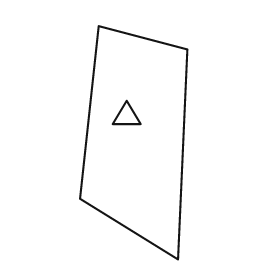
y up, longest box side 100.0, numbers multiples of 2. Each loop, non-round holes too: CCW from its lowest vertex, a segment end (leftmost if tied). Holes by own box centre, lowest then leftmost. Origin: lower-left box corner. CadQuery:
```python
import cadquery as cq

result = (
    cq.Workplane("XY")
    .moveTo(42.0, 0.0)
    .lineTo(46.0, 90.0)
    .lineTo(8.0, 100.0)
    .lineTo(0.0, 26.0)
    .close()
    .moveTo(14.0, 58.0)
    .lineTo(26.0, 58.0)
    .lineTo(20.0, 68.0)
    .close()
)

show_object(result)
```